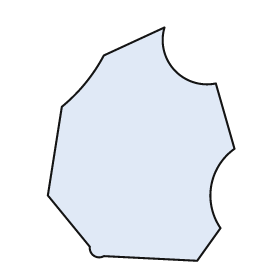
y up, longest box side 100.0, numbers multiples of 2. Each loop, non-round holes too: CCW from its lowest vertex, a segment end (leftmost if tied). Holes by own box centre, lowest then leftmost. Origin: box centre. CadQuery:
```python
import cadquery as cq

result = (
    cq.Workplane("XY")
    .moveTo(24.0, -50.0)
    .lineTo(34.0, -36.0)
    .threePointArc((30.0, -18.0), (40.0, -2.0))
    .lineTo(32.0, 26.0)
    .threePointArc((14.0, 32.0), (10.0, 50.0))
    .lineTo(-16.0, 38.0)
    .threePointArc((-24.0, 26.0), (-34.0, 16.0))
    .lineTo(-40.0, -22.0)
    .lineTo(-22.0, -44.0)
    .threePointArc((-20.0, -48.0), (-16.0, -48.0))
    .close()
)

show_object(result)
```